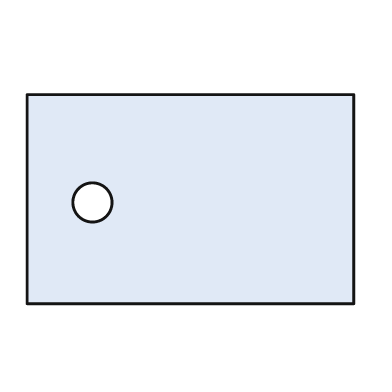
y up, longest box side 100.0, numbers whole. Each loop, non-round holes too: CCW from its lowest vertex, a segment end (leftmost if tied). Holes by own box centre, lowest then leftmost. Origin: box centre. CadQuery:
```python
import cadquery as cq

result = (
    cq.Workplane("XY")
    .moveTo(-50.0, -32.0)
    .lineTo(50.0, -32.0)
    .lineTo(50.0, 32.0)
    .lineTo(-50.0, 32.0)
    .close()
    .moveTo(-30.0, -1.0)
    .circle(6.0)
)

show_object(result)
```